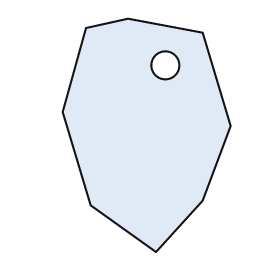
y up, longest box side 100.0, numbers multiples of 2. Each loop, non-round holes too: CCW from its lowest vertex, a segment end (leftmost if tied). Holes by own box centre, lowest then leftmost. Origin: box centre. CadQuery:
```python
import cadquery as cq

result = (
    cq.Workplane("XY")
    .moveTo(4.0, -50.0)
    .lineTo(24.0, -28.0)
    .lineTo(36.0, 4.0)
    .lineTo(24.0, 44.0)
    .lineTo(-8.0, 50.0)
    .lineTo(-26.0, 46.0)
    .lineTo(-36.0, 10.0)
    .lineTo(-24.0, -30.0)
    .close()
    .moveTo(8.0, 30.0)
    .circle(6.0)
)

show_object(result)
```